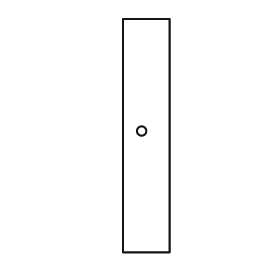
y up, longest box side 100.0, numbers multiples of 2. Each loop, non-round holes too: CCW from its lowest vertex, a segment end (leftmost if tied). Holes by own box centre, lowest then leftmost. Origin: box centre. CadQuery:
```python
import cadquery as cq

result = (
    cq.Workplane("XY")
    .moveTo(-10.0, -50.0)
    .lineTo(10.0, -50.0)
    .lineTo(10.0, 50.0)
    .lineTo(-10.0, 50.0)
    .close()
    .moveTo(-2.0, 2.0)
    .circle(2.0)
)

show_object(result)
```